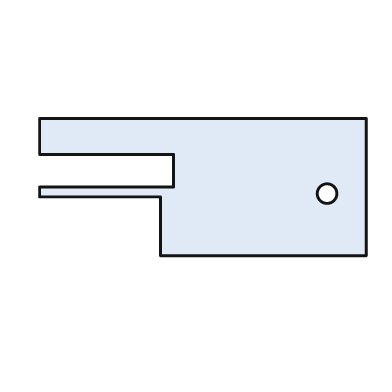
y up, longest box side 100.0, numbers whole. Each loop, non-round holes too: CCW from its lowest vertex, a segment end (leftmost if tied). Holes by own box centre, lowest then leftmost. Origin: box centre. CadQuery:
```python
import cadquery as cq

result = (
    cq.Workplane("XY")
    .moveTo(-13.0, -21.0)
    .lineTo(50.0, -21.0)
    .lineTo(50.0, 21.0)
    .lineTo(-50.0, 21.0)
    .lineTo(-50.0, 10.0)
    .lineTo(-9.0, 10.0)
    .lineTo(-9.0, 0.0)
    .lineTo(-50.0, 0.0)
    .lineTo(-50.0, -3.0)
    .lineTo(-13.0, -3.0)
    .close()
    .moveTo(38.0, -2.0)
    .circle(3.0)
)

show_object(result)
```